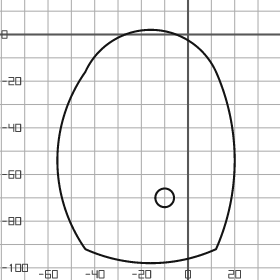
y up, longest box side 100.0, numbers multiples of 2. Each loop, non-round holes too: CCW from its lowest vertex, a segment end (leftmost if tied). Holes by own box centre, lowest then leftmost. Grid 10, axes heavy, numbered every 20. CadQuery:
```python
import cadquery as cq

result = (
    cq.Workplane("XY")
    .moveTo(-44.0, -92.0)
    .threePointArc((-16.0, -98.0), (12.0, -92.0))
    .threePointArc((20.0, -54.0), (12.0, -16.0))
    .threePointArc((-16.0, 2.0), (-44.0, -16.0))
    .threePointArc((-56.0, -54.0), (-44.0, -92.0))
    .close()
    .moveTo(-10.0, -70.0)
    .circle(4.0)
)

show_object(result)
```